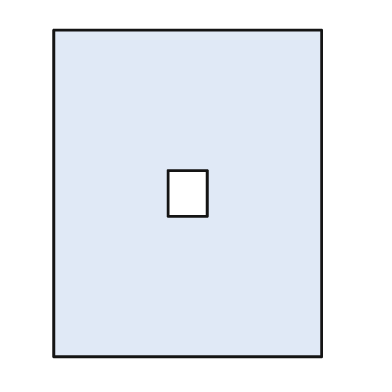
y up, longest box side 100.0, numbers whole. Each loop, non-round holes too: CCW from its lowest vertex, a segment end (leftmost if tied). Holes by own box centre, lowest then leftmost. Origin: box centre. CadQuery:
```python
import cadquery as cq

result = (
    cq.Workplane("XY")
    .moveTo(-41.0, -50.0)
    .lineTo(41.0, -50.0)
    .lineTo(41.0, 50.0)
    .lineTo(-41.0, 50.0)
    .close()
    .moveTo(-6.0, -7.0)
    .lineTo(6.0, -7.0)
    .lineTo(6.0, 7.0)
    .lineTo(-6.0, 7.0)
    .close()
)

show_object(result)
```